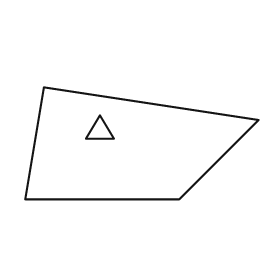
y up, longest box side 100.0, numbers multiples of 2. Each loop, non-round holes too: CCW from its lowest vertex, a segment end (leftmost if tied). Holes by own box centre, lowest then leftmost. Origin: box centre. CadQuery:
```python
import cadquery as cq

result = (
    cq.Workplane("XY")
    .moveTo(-50.0, -24.0)
    .lineTo(16.0, -24.0)
    .lineTo(50.0, 10.0)
    .lineTo(-42.0, 24.0)
    .close()
    .moveTo(-24.0, 2.0)
    .lineTo(-12.0, 2.0)
    .lineTo(-18.0, 12.0)
    .close()
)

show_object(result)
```